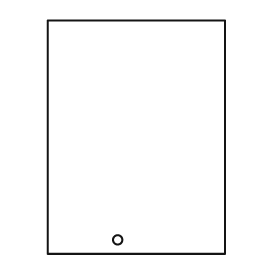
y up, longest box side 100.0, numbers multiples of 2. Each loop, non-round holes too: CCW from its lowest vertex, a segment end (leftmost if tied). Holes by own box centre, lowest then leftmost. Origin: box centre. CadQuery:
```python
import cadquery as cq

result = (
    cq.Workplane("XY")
    .moveTo(-38.0, -50.0)
    .lineTo(38.0, -50.0)
    .lineTo(38.0, 50.0)
    .lineTo(-38.0, 50.0)
    .close()
    .moveTo(-8.0, -44.0)
    .circle(2.0)
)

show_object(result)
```